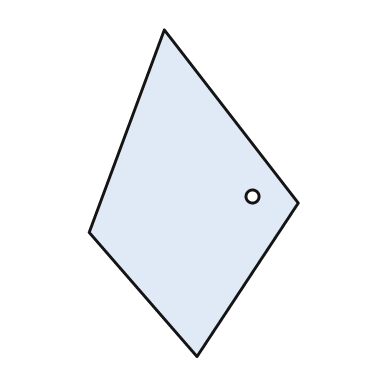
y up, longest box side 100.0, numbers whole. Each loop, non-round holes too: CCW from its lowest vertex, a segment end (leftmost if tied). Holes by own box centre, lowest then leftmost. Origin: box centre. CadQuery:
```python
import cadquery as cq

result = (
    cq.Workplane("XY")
    .moveTo(1.0, -50.0)
    .lineTo(32.0, -3.0)
    .lineTo(-9.0, 50.0)
    .lineTo(-32.0, -12.0)
    .close()
    .moveTo(18.0, -1.0)
    .circle(2.0)
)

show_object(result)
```